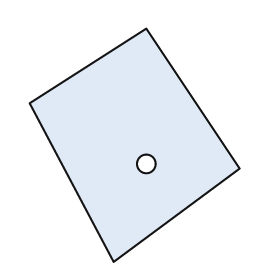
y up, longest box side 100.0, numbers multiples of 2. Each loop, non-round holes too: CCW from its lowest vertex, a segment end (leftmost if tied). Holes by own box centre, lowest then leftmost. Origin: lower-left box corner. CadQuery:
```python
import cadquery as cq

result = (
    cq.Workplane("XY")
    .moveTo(36.0, 0.0)
    .lineTo(90.0, 40.0)
    .lineTo(50.0, 100.0)
    .lineTo(0.0, 68.0)
    .close()
    .moveTo(50.0, 42.0)
    .circle(4.0)
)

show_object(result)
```